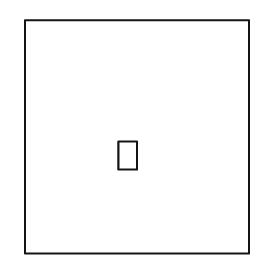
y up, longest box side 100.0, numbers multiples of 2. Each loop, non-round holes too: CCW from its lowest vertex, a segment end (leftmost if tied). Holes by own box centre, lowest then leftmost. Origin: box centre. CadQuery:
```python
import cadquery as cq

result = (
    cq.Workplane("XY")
    .moveTo(-48.0, -50.0)
    .lineTo(48.0, -50.0)
    .lineTo(48.0, 50.0)
    .lineTo(-48.0, 50.0)
    .close()
    .moveTo(-8.0, -14.0)
    .lineTo(0.0, -14.0)
    .lineTo(0.0, -2.0)
    .lineTo(-8.0, -2.0)
    .close()
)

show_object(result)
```